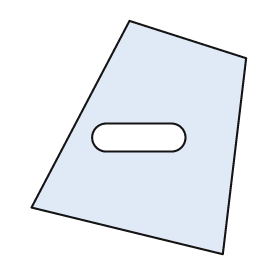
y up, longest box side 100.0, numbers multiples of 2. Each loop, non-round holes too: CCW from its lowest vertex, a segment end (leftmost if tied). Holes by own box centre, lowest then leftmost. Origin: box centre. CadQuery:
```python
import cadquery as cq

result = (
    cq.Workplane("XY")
    .moveTo(36.0, -50.0)
    .lineTo(46.0, 34.0)
    .lineTo(-4.0, 50.0)
    .lineTo(-46.0, -30.0)
    .close()
    .moveTo(-14.0, -6.0)
    .lineTo(14.0, -6.0)
    .threePointArc((20.0, 0.0), (14.0, 6.0))
    .lineTo(-14.0, 6.0)
    .threePointArc((-20.0, 0.0), (-14.0, -6.0))
    .close()
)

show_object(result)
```